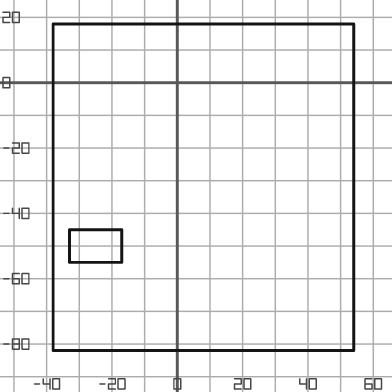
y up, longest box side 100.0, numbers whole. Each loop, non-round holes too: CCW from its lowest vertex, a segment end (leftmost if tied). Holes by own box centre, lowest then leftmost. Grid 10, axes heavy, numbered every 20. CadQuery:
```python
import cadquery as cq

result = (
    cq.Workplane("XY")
    .moveTo(-38.0, -82.0)
    .lineTo(54.0, -82.0)
    .lineTo(54.0, 18.0)
    .lineTo(-38.0, 18.0)
    .close()
    .moveTo(-33.0, -55.0)
    .lineTo(-17.0, -55.0)
    .lineTo(-17.0, -45.0)
    .lineTo(-33.0, -45.0)
    .close()
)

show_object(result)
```